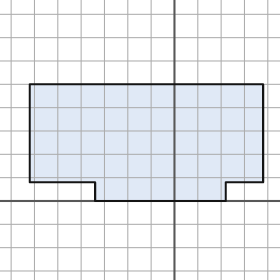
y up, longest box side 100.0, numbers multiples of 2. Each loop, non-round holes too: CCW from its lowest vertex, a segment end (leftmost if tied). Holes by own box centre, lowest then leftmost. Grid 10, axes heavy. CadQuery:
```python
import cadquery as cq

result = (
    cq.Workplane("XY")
    .moveTo(-34.0, 0.0)
    .lineTo(22.0, 0.0)
    .lineTo(22.0, 8.0)
    .lineTo(38.0, 8.0)
    .lineTo(38.0, 50.0)
    .lineTo(-62.0, 50.0)
    .lineTo(-62.0, 8.0)
    .lineTo(-34.0, 8.0)
    .close()
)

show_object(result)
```